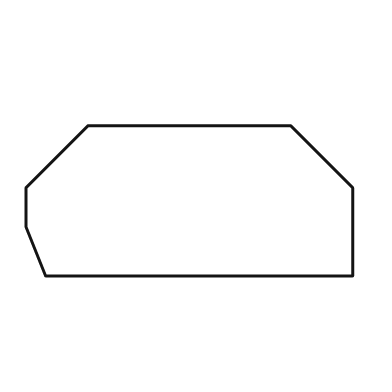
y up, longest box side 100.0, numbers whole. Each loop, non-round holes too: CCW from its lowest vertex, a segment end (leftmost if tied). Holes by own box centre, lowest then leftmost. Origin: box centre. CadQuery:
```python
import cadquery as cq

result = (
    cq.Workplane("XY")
    .moveTo(-44.0, -23.0)
    .lineTo(50.0, -23.0)
    .lineTo(50.0, 4.0)
    .lineTo(31.0, 23.0)
    .lineTo(-31.0, 23.0)
    .lineTo(-50.0, 4.0)
    .lineTo(-50.0, -8.0)
    .close()
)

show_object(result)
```